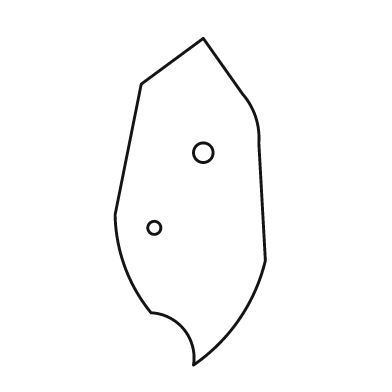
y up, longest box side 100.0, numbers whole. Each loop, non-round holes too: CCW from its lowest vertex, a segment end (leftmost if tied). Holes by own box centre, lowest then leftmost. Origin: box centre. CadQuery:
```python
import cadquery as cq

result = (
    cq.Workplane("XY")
    .moveTo(1.0, -50.0)
    .threePointArc((15.0, -36.0), (23.0, -18.0))
    .lineTo(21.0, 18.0)
    .threePointArc((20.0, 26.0), (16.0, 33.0))
    .lineTo(4.0, 50.0)
    .lineTo(-15.0, 36.0)
    .lineTo(-23.0, -4.0)
    .threePointArc((-20.0, -20.0), (-12.0, -34.0))
    .threePointArc((-2.0, -39.0), (1.0, -50.0))
    .close()
    .moveTo(-11.0, -8.0)
    .circle(2.0)
    .moveTo(4.0, 15.0)
    .circle(3.0)
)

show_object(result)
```